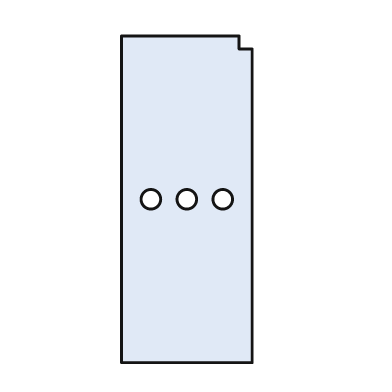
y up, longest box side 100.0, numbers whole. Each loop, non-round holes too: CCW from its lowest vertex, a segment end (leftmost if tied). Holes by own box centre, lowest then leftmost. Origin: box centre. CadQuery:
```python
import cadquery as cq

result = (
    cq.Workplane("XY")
    .moveTo(-20.0, -50.0)
    .lineTo(20.0, -50.0)
    .lineTo(20.0, 46.0)
    .lineTo(16.0, 46.0)
    .lineTo(16.0, 50.0)
    .lineTo(-20.0, 50.0)
    .close()
    .moveTo(-11.0, 0.0)
    .circle(3.0)
    .moveTo(0.0, 0.0)
    .circle(3.0)
    .moveTo(11.0, 0.0)
    .circle(3.0)
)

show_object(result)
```